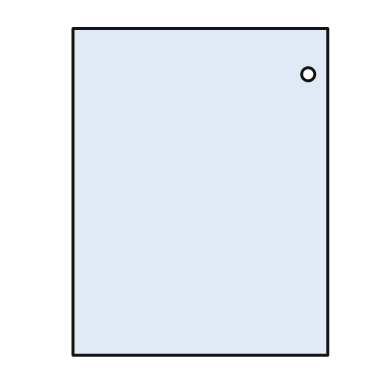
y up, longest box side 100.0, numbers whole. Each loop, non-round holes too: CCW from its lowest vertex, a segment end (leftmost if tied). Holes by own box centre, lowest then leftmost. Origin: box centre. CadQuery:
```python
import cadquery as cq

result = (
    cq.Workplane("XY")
    .moveTo(-39.0, -50.0)
    .lineTo(39.0, -50.0)
    .lineTo(39.0, 50.0)
    .lineTo(-39.0, 50.0)
    .close()
    .moveTo(33.0, 36.0)
    .circle(2.0)
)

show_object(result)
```